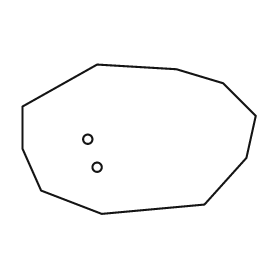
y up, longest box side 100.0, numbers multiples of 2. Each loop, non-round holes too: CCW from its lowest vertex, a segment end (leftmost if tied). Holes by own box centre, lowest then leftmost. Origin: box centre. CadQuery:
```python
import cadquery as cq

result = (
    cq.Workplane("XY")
    .moveTo(-16.0, -32.0)
    .lineTo(28.0, -28.0)
    .lineTo(46.0, -8.0)
    .lineTo(50.0, 10.0)
    .lineTo(36.0, 24.0)
    .lineTo(16.0, 30.0)
    .lineTo(-18.0, 32.0)
    .lineTo(-50.0, 14.0)
    .lineTo(-50.0, -4.0)
    .lineTo(-42.0, -22.0)
    .close()
    .moveTo(-18.0, -12.0)
    .circle(2.0)
    .moveTo(-22.0, 0.0)
    .circle(2.0)
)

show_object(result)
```